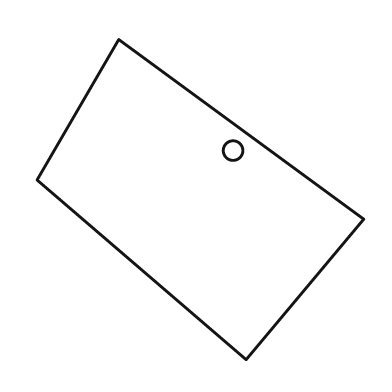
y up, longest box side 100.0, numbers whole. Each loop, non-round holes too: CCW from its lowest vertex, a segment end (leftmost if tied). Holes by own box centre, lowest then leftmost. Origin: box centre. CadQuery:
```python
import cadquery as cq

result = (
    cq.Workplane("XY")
    .moveTo(14.0, -49.0)
    .lineTo(50.0, -6.0)
    .lineTo(-25.0, 49.0)
    .lineTo(-50.0, 6.0)
    .close()
    .moveTo(10.0, 15.0)
    .circle(3.0)
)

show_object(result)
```